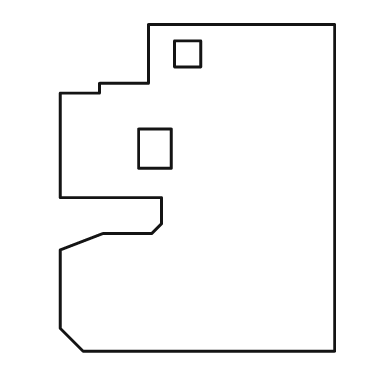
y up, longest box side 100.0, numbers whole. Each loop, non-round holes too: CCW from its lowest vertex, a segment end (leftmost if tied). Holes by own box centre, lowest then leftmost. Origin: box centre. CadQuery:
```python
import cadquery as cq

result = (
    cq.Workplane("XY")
    .moveTo(-35.0, -50.0)
    .lineTo(42.0, -50.0)
    .lineTo(42.0, 50.0)
    .lineTo(-15.0, 50.0)
    .lineTo(-15.0, 32.0)
    .lineTo(-30.0, 32.0)
    .lineTo(-30.0, 29.0)
    .lineTo(-42.0, 29.0)
    .lineTo(-42.0, -3.0)
    .lineTo(-11.0, -3.0)
    .lineTo(-11.0, -11.0)
    .lineTo(-14.0, -14.0)
    .lineTo(-29.0, -14.0)
    .lineTo(-42.0, -19.0)
    .lineTo(-42.0, -43.0)
    .close()
    .moveTo(-18.0, 6.0)
    .lineTo(-8.0, 6.0)
    .lineTo(-8.0, 18.0)
    .lineTo(-18.0, 18.0)
    .close()
    .moveTo(-7.0, 37.0)
    .lineTo(1.0, 37.0)
    .lineTo(1.0, 45.0)
    .lineTo(-7.0, 45.0)
    .close()
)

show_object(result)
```